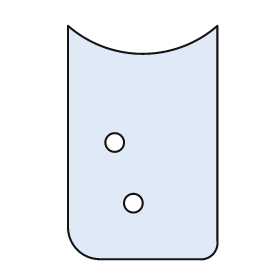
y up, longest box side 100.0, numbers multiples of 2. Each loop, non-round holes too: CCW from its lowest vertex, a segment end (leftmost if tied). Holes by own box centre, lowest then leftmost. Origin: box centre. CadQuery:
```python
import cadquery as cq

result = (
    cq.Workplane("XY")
    .moveTo(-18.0, -50.0)
    .lineTo(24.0, -50.0)
    .threePointArc((30.0, -48.0), (32.0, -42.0))
    .lineTo(32.0, 50.0)
    .threePointArc((0.0, 38.0), (-32.0, 50.0))
    .lineTo(-32.0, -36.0)
    .threePointArc((-28.0, -46.0), (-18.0, -50.0))
    .close()
    .moveTo(-4.0, -26.0)
    .circle(4.0)
    .moveTo(-12.0, 0.0)
    .circle(4.0)
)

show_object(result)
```